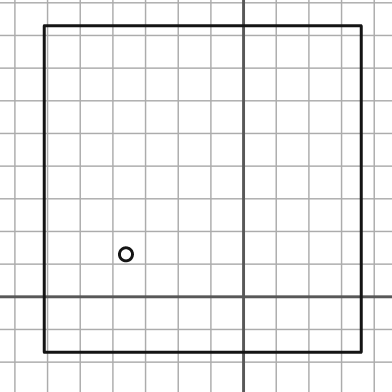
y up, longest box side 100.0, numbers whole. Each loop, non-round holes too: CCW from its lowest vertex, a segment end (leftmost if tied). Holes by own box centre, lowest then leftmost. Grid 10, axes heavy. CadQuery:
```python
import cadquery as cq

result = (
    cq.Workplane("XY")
    .moveTo(-61.0, -17.0)
    .lineTo(36.0, -17.0)
    .lineTo(36.0, 83.0)
    .lineTo(-61.0, 83.0)
    .close()
    .moveTo(-36.0, 13.0)
    .circle(2.0)
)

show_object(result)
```